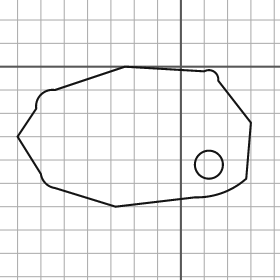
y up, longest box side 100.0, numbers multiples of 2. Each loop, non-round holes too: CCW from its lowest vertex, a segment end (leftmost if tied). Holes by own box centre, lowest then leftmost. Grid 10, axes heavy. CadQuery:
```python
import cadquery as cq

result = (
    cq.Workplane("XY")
    .moveTo(-28.0, -60.0)
    .lineTo(6.0, -56.0)
    .threePointArc((18.0, -54.0), (28.0, -48.0))
    .lineTo(30.0, -24.0)
    .lineTo(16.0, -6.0)
    .threePointArc((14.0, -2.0), (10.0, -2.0))
    .lineTo(-24.0, 0.0)
    .lineTo(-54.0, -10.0)
    .threePointArc((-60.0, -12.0), (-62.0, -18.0))
    .lineTo(-70.0, -30.0)
    .lineTo(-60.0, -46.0)
    .threePointArc((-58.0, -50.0), (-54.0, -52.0))
    .close()
    .moveTo(12.0, -42.0)
    .circle(6.0)
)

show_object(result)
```